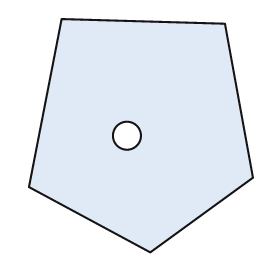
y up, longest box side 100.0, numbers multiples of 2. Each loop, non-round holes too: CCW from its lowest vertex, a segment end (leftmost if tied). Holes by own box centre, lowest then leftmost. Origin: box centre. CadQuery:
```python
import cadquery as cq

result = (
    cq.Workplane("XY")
    .moveTo(4.0, -50.0)
    .lineTo(48.0, -18.0)
    .lineTo(36.0, 48.0)
    .lineTo(-34.0, 50.0)
    .lineTo(-48.0, -22.0)
    .close()
    .moveTo(-6.0, 0.0)
    .circle(6.0)
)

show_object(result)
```